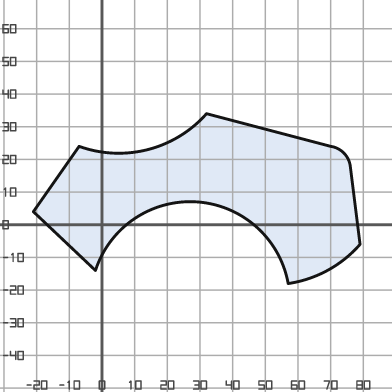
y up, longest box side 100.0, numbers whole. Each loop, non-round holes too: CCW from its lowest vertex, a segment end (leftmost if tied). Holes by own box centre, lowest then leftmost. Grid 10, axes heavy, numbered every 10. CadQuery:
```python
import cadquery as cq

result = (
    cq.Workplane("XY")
    .moveTo(57.0, -18.0)
    .threePointArc((69.0, -14.0), (79.0, -6.0))
    .lineTo(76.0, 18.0)
    .threePointArc((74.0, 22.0), (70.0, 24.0))
    .lineTo(32.0, 34.0)
    .threePointArc((14.0, 23.0), (-7.0, 24.0))
    .lineTo(-21.0, 4.0)
    .lineTo(-2.0, -14.0)
    .threePointArc((29.0, 7.0), (57.0, -18.0))
    .close()
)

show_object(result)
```